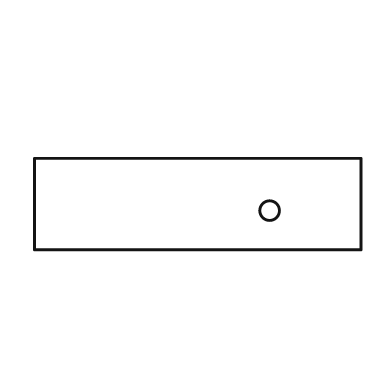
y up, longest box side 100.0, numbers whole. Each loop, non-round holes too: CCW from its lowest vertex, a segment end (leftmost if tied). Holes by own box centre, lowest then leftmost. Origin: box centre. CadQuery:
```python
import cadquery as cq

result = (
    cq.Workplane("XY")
    .moveTo(-50.0, -14.0)
    .lineTo(50.0, -14.0)
    .lineTo(50.0, 14.0)
    .lineTo(-50.0, 14.0)
    .close()
    .moveTo(22.0, -2.0)
    .circle(3.0)
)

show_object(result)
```